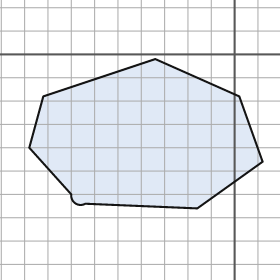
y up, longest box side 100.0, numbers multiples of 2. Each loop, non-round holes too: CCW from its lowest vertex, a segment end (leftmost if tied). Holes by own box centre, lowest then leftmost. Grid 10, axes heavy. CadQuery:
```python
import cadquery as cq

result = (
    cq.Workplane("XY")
    .moveTo(-16.0, -66.0)
    .lineTo(12.0, -46.0)
    .lineTo(2.0, -18.0)
    .lineTo(-34.0, -2.0)
    .lineTo(-82.0, -18.0)
    .lineTo(-88.0, -40.0)
    .lineTo(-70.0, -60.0)
    .threePointArc((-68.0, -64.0), (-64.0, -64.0))
    .close()
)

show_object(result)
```